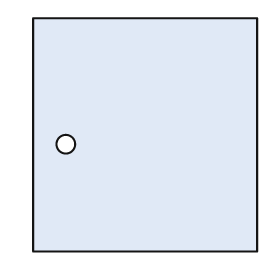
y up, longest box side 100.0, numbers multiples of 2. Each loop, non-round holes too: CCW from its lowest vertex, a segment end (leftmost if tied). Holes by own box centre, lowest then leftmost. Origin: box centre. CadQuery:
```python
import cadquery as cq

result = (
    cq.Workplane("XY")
    .moveTo(-48.0, -50.0)
    .lineTo(48.0, -50.0)
    .lineTo(48.0, 50.0)
    .lineTo(-48.0, 50.0)
    .close()
    .moveTo(-34.0, -4.0)
    .circle(4.0)
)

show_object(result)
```